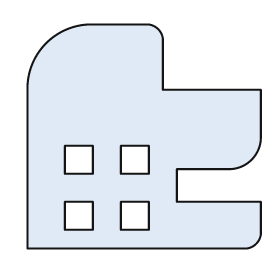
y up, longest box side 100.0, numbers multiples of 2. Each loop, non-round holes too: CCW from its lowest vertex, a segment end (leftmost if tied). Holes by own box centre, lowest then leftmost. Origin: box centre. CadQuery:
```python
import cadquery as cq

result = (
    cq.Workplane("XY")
    .moveTo(-50.0, -48.0)
    .lineTo(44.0, -48.0)
    .threePointArc((48.0, -46.0), (50.0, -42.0))
    .lineTo(50.0, -28.0)
    .lineTo(14.0, -28.0)
    .lineTo(14.0, -14.0)
    .lineTo(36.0, -14.0)
    .threePointArc((46.0, -10.0), (50.0, 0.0))
    .lineTo(50.0, 20.0)
    .lineTo(8.0, 20.0)
    .lineTo(8.0, 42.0)
    .threePointArc((6.0, 46.0), (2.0, 48.0))
    .lineTo(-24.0, 48.0)
    .threePointArc((-42.0, 40.0), (-50.0, 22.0))
    .close()
    .moveTo(-34.0, -40.0)
    .lineTo(-22.0, -40.0)
    .lineTo(-22.0, -28.0)
    .lineTo(-34.0, -28.0)
    .close()
    .moveTo(-10.0, -40.0)
    .lineTo(2.0, -40.0)
    .lineTo(2.0, -28.0)
    .lineTo(-10.0, -28.0)
    .close()
    .moveTo(-34.0, -16.0)
    .lineTo(-22.0, -16.0)
    .lineTo(-22.0, -4.0)
    .lineTo(-34.0, -4.0)
    .close()
    .moveTo(-10.0, -16.0)
    .lineTo(2.0, -16.0)
    .lineTo(2.0, -4.0)
    .lineTo(-10.0, -4.0)
    .close()
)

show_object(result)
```